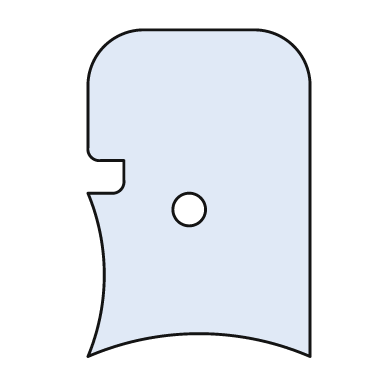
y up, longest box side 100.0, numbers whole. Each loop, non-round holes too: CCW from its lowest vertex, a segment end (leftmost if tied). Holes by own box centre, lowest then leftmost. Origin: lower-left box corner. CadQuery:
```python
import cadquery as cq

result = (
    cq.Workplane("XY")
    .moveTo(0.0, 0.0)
    .threePointArc((34.0, 7.0), (68.0, 0.0))
    .lineTo(68.0, 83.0)
    .threePointArc((63.0, 95.0), (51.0, 100.0))
    .lineTo(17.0, 100.0)
    .threePointArc((5.0, 95.0), (0.0, 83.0))
    .lineTo(0.0, 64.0)
    .threePointArc((1.0, 61.0), (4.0, 60.0))
    .lineTo(11.0, 60.0)
    .lineTo(11.0, 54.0)
    .threePointArc((10.0, 51.0), (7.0, 50.0))
    .lineTo(0.0, 50.0)
    .threePointArc((5.0, 25.0), (0.0, 0.0))
    .close()
    .moveTo(31.0, 45.0)
    .circle(5.0)
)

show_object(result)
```